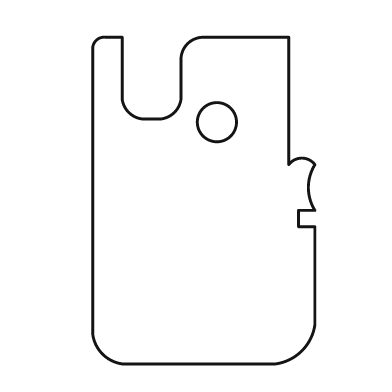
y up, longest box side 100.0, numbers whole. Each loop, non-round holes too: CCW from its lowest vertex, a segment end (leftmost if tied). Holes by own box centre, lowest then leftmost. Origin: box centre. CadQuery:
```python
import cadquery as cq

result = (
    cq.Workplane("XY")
    .moveTo(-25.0, -50.0)
    .lineTo(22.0, -50.0)
    .threePointArc((30.0, -46.0), (34.0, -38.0))
    .lineTo(34.0, -8.0)
    .lineTo(29.0, -8.0)
    .lineTo(29.0, -3.0)
    .lineTo(34.0, -3.0)
    .threePointArc((32.0, 4.0), (34.0, 11.0))
    .threePointArc((30.0, 13.0), (26.0, 11.0))
    .lineTo(26.0, 50.0)
    .lineTo(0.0, 50.0)
    .threePointArc((-5.0, 48.0), (-7.0, 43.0))
    .lineTo(-7.0, 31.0)
    .threePointArc((-9.0, 27.0), (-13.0, 25.0))
    .lineTo(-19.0, 25.0)
    .threePointArc((-23.0, 27.0), (-25.0, 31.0))
    .lineTo(-25.0, 50.0)
    .lineTo(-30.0, 50.0)
    .threePointArc((-33.0, 49.0), (-34.0, 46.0))
    .lineTo(-34.0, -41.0)
    .threePointArc((-31.0, -47.0), (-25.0, -50.0))
    .close()
    .moveTo(4.0, 24.0)
    .circle(6.0)
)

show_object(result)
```